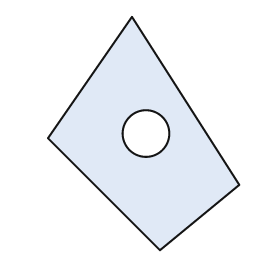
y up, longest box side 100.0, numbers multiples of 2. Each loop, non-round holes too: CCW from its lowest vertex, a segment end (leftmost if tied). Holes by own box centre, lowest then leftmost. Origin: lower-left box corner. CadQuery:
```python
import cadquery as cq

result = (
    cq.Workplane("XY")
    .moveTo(48.0, 0.0)
    .lineTo(82.0, 28.0)
    .lineTo(36.0, 100.0)
    .lineTo(0.0, 48.0)
    .close()
    .moveTo(42.0, 50.0)
    .circle(10.0)
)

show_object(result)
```